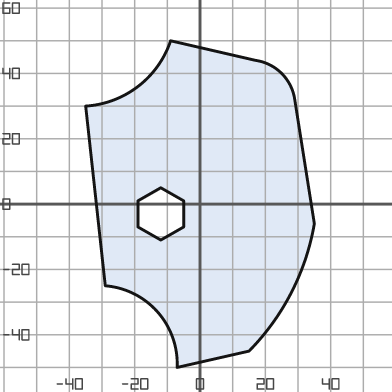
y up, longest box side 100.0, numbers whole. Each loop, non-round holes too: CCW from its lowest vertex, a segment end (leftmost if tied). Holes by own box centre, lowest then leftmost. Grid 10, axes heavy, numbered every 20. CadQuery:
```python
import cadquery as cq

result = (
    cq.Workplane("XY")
    .moveTo(-7.0, -50.0)
    .lineTo(15.0, -45.0)
    .threePointArc((28.0, -27.0), (35.0, -6.0))
    .lineTo(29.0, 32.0)
    .threePointArc((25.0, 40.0), (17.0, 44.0))
    .lineTo(-9.0, 50.0)
    .threePointArc((-19.0, 36.0), (-35.0, 30.0))
    .lineTo(-29.0, -25.0)
    .threePointArc((-13.0, -33.0), (-7.0, -50.0))
    .close()
    .moveTo(-12.0, -11.0)
    .lineTo(-5.0, -7.0)
    .lineTo(-5.0, 1.0)
    .lineTo(-12.0, 5.0)
    .lineTo(-19.0, 1.0)
    .lineTo(-19.0, -7.0)
    .close()
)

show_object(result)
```